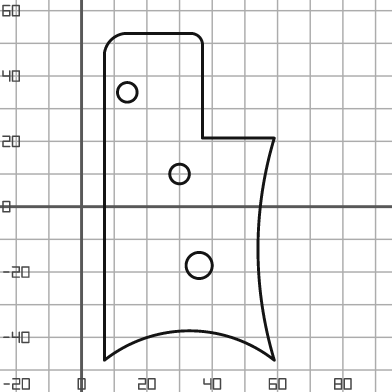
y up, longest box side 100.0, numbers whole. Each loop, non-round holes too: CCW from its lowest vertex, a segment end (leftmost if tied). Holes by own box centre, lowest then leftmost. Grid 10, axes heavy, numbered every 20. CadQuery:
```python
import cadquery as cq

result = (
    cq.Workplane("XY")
    .moveTo(7.0, -47.0)
    .threePointArc((33.0, -38.0), (59.0, -47.0))
    .threePointArc((54.0, -13.0), (59.0, 21.0))
    .lineTo(37.0, 21.0)
    .lineTo(37.0, 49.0)
    .threePointArc((36.0, 52.0), (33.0, 53.0))
    .lineTo(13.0, 53.0)
    .threePointArc((9.0, 51.0), (7.0, 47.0))
    .close()
    .moveTo(36.0, -18.0)
    .circle(4.0)
    .moveTo(30.0, 10.0)
    .circle(3.0)
    .moveTo(14.0, 35.0)
    .circle(3.0)
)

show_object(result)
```